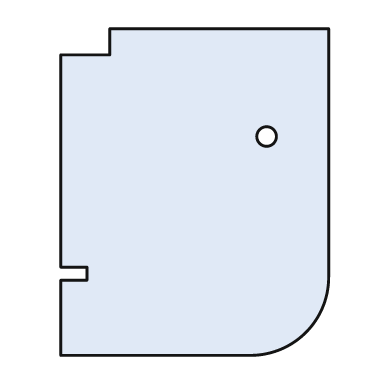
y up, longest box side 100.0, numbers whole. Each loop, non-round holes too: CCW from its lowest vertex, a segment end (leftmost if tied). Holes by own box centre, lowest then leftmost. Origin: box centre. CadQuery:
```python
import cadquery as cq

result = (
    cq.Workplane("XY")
    .moveTo(-41.0, -50.0)
    .lineTo(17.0, -50.0)
    .threePointArc((34.0, -43.0), (41.0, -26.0))
    .lineTo(41.0, 50.0)
    .lineTo(-26.0, 50.0)
    .lineTo(-26.0, 42.0)
    .lineTo(-41.0, 42.0)
    .lineTo(-41.0, -23.0)
    .lineTo(-33.0, -23.0)
    .lineTo(-33.0, -27.0)
    .lineTo(-41.0, -27.0)
    .close()
    .moveTo(22.0, 17.0)
    .circle(3.0)
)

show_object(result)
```